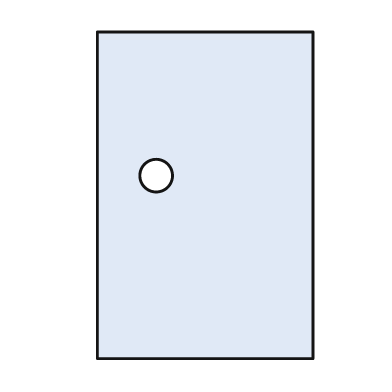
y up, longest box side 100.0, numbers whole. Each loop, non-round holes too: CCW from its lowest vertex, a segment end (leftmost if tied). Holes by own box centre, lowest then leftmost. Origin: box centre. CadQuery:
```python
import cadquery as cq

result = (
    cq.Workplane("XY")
    .moveTo(-33.0, -50.0)
    .lineTo(33.0, -50.0)
    .lineTo(33.0, 50.0)
    .lineTo(-33.0, 50.0)
    .close()
    .moveTo(-15.0, 6.0)
    .circle(5.0)
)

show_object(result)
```